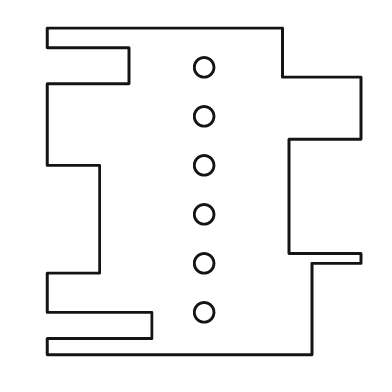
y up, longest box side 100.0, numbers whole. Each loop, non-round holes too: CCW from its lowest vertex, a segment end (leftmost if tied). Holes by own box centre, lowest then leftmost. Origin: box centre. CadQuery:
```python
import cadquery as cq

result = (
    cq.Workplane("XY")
    .moveTo(-48.0, -50.0)
    .lineTo(33.0, -50.0)
    .lineTo(33.0, -22.0)
    .lineTo(48.0, -22.0)
    .lineTo(48.0, -19.0)
    .lineTo(26.0, -19.0)
    .lineTo(26.0, 16.0)
    .lineTo(48.0, 16.0)
    .lineTo(48.0, 35.0)
    .lineTo(24.0, 35.0)
    .lineTo(24.0, 50.0)
    .lineTo(-48.0, 50.0)
    .lineTo(-48.0, 44.0)
    .lineTo(-23.0, 44.0)
    .lineTo(-23.0, 33.0)
    .lineTo(-48.0, 33.0)
    .lineTo(-48.0, 8.0)
    .lineTo(-32.0, 8.0)
    .lineTo(-32.0, -25.0)
    .lineTo(-48.0, -25.0)
    .lineTo(-48.0, -37.0)
    .lineTo(-16.0, -37.0)
    .lineTo(-16.0, -45.0)
    .lineTo(-48.0, -45.0)
    .close()
    .moveTo(0.0, -37.0)
    .circle(3.0)
    .moveTo(0.0, -22.0)
    .circle(3.0)
    .moveTo(0.0, -7.0)
    .circle(3.0)
    .moveTo(0.0, 8.0)
    .circle(3.0)
    .moveTo(0.0, 23.0)
    .circle(3.0)
    .moveTo(0.0, 38.0)
    .circle(3.0)
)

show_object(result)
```